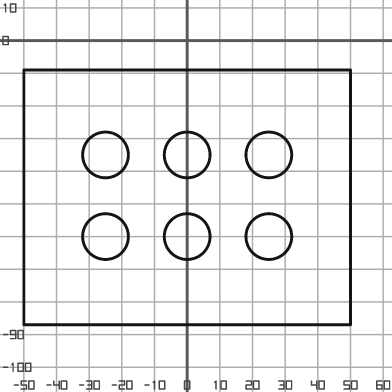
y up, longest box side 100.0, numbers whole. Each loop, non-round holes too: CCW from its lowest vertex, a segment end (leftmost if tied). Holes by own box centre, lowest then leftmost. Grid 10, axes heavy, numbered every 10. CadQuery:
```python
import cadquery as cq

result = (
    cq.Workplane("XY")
    .moveTo(-50.0, -87.0)
    .lineTo(50.0, -87.0)
    .lineTo(50.0, -9.0)
    .lineTo(-50.0, -9.0)
    .close()
    .moveTo(-25.0, -60.0)
    .circle(7.0)
    .moveTo(0.0, -60.0)
    .circle(7.0)
    .moveTo(25.0, -60.0)
    .circle(7.0)
    .moveTo(-25.0, -35.0)
    .circle(7.0)
    .moveTo(0.0, -35.0)
    .circle(7.0)
    .moveTo(25.0, -35.0)
    .circle(7.0)
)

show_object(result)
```